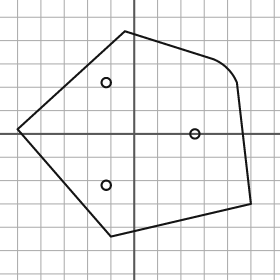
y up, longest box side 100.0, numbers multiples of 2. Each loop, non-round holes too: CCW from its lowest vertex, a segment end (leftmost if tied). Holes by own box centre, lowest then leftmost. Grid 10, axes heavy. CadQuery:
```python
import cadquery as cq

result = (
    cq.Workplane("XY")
    .moveTo(-10.0, -44.0)
    .lineTo(50.0, -30.0)
    .lineTo(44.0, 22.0)
    .threePointArc((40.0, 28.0), (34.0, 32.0))
    .lineTo(-4.0, 44.0)
    .lineTo(-50.0, 2.0)
    .close()
    .moveTo(-12.0, -22.0)
    .circle(2.0)
    .moveTo(26.0, 0.0)
    .circle(2.0)
    .moveTo(-12.0, 22.0)
    .circle(2.0)
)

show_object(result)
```